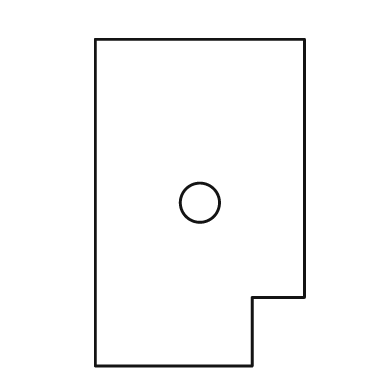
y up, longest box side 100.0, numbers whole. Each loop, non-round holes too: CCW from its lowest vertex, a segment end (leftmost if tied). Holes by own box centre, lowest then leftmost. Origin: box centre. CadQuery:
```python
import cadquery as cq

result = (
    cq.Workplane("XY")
    .moveTo(-32.0, -50.0)
    .lineTo(16.0, -50.0)
    .lineTo(16.0, -29.0)
    .lineTo(32.0, -29.0)
    .lineTo(32.0, 50.0)
    .lineTo(-32.0, 50.0)
    .close()
    .moveTo(0.0, 0.0)
    .circle(6.0)
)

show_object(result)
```